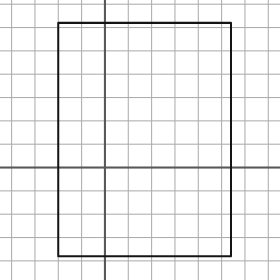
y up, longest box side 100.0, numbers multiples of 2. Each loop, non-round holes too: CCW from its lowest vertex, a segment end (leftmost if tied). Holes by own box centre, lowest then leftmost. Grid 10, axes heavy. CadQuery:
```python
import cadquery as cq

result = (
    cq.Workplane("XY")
    .moveTo(-20.0, -38.0)
    .lineTo(54.0, -38.0)
    .lineTo(54.0, 62.0)
    .lineTo(-20.0, 62.0)
    .close()
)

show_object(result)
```